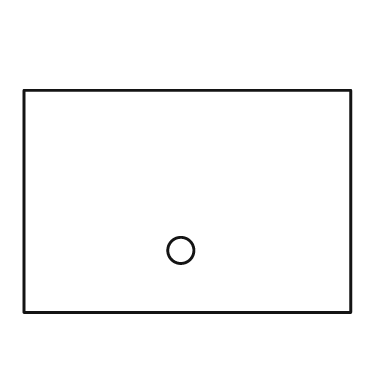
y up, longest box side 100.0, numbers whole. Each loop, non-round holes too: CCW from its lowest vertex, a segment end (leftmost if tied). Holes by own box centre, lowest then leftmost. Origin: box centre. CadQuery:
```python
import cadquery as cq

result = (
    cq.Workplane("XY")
    .moveTo(-50.0, -34.0)
    .lineTo(50.0, -34.0)
    .lineTo(50.0, 34.0)
    .lineTo(-50.0, 34.0)
    .close()
    .moveTo(-2.0, -15.0)
    .circle(4.0)
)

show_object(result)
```